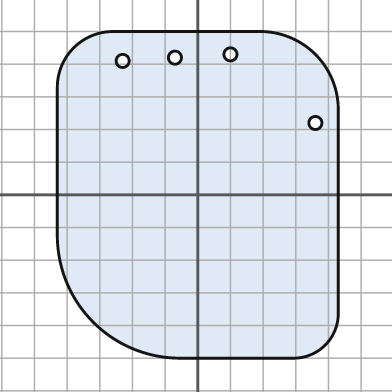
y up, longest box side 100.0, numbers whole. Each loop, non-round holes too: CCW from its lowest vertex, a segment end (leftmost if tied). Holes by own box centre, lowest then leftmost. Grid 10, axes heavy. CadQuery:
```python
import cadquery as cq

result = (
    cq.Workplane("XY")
    .moveTo(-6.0, -50.0)
    .lineTo(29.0, -50.0)
    .threePointArc((39.0, -46.0), (43.0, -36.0))
    .lineTo(43.0, 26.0)
    .threePointArc((36.0, 43.0), (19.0, 50.0))
    .lineTo(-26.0, 50.0)
    .threePointArc((-38.0, 45.0), (-43.0, 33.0))
    .lineTo(-43.0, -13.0)
    .threePointArc((-32.0, -39.0), (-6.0, -50.0))
    .close()
    .moveTo(36.0, 22.0)
    .circle(2.0)
    .moveTo(-23.0, 41.0)
    .circle(2.0)
    .moveTo(-7.0, 42.0)
    .circle(2.0)
    .moveTo(10.0, 43.0)
    .circle(2.0)
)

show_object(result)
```